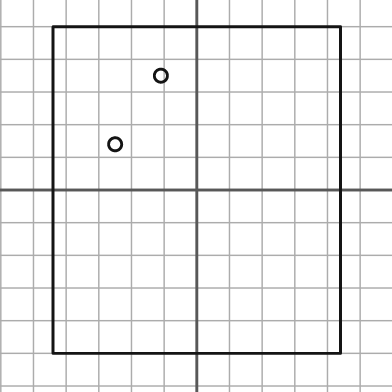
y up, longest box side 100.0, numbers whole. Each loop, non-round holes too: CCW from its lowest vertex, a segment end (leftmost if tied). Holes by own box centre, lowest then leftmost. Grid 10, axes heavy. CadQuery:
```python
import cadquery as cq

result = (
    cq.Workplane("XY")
    .moveTo(-44.0, -50.0)
    .lineTo(44.0, -50.0)
    .lineTo(44.0, 50.0)
    .lineTo(-44.0, 50.0)
    .close()
    .moveTo(-25.0, 14.0)
    .circle(2.0)
    .moveTo(-11.0, 35.0)
    .circle(2.0)
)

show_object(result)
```